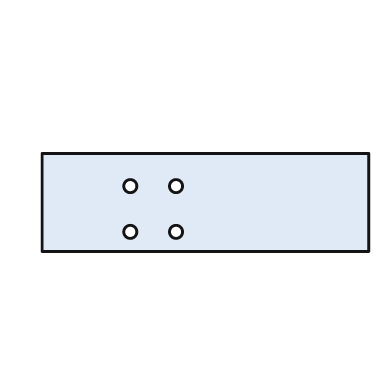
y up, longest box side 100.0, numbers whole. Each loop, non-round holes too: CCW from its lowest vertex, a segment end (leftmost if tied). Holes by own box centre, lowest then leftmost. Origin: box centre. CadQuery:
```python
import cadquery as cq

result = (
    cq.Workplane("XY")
    .moveTo(-50.0, -15.0)
    .lineTo(50.0, -15.0)
    .lineTo(50.0, 15.0)
    .lineTo(-50.0, 15.0)
    .close()
    .moveTo(-23.0, -9.0)
    .circle(2.0)
    .moveTo(-9.0, -9.0)
    .circle(2.0)
    .moveTo(-23.0, 5.0)
    .circle(2.0)
    .moveTo(-9.0, 5.0)
    .circle(2.0)
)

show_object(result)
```